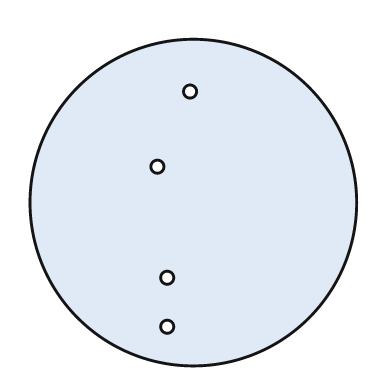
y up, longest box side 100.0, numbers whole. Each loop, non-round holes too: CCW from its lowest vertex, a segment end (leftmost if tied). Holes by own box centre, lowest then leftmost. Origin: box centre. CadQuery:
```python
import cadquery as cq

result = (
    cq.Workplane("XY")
    .moveTo(0.0, 0.0)
    .circle(50.0)
    .moveTo(-8.0, -38.0)
    .circle(2.0)
    .moveTo(-8.0, -23.0)
    .circle(2.0)
    .moveTo(-11.0, 11.0)
    .circle(2.0)
    .moveTo(-1.0, 34.0)
    .circle(2.0)
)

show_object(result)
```